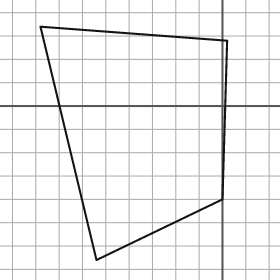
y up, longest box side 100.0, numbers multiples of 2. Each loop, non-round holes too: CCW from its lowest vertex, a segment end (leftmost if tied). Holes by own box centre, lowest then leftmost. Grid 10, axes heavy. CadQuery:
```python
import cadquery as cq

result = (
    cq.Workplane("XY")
    .moveTo(-54.0, -66.0)
    .lineTo(0.0, -40.0)
    .lineTo(2.0, 28.0)
    .lineTo(-78.0, 34.0)
    .close()
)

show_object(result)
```